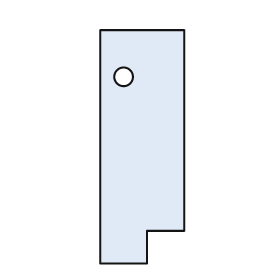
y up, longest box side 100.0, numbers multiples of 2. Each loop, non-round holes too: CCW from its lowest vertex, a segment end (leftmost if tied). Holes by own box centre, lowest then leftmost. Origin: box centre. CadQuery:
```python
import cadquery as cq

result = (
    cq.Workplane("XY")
    .moveTo(-18.0, -50.0)
    .lineTo(2.0, -50.0)
    .lineTo(2.0, -36.0)
    .lineTo(18.0, -36.0)
    .lineTo(18.0, 50.0)
    .lineTo(-18.0, 50.0)
    .close()
    .moveTo(-8.0, 30.0)
    .circle(4.0)
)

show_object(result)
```